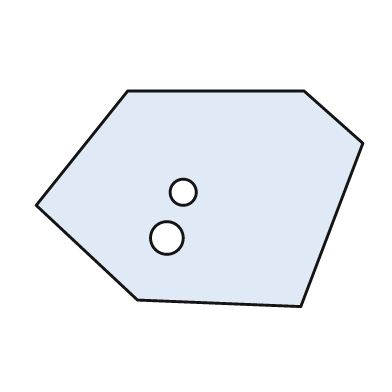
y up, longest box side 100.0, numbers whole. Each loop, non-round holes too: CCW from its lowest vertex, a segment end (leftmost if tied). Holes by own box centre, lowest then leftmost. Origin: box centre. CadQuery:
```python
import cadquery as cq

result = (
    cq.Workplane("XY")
    .moveTo(31.0, -33.0)
    .lineTo(50.0, 17.0)
    .lineTo(32.0, 33.0)
    .lineTo(-22.0, 33.0)
    .lineTo(-50.0, -2.0)
    .lineTo(-19.0, -31.0)
    .close()
    .moveTo(-10.0, -12.0)
    .circle(5.0)
    .moveTo(-5.0, 2.0)
    .circle(4.0)
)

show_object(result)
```